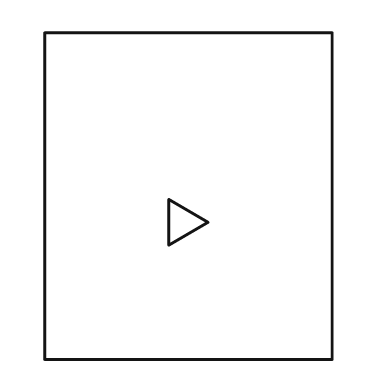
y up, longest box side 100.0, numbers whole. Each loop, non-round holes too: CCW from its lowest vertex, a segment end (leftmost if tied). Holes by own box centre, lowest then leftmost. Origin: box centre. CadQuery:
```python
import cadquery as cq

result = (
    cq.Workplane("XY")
    .moveTo(-44.0, -50.0)
    .lineTo(44.0, -50.0)
    .lineTo(44.0, 50.0)
    .lineTo(-44.0, 50.0)
    .close()
    .moveTo(-6.0, -15.0)
    .lineTo(6.0, -8.0)
    .lineTo(-6.0, -1.0)
    .close()
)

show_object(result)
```